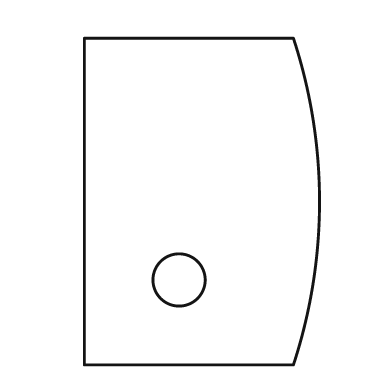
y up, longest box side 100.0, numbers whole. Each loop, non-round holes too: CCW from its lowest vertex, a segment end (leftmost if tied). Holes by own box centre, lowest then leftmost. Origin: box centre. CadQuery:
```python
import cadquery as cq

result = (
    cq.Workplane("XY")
    .moveTo(-36.0, -50.0)
    .lineTo(28.0, -50.0)
    .threePointArc((36.0, 0.0), (28.0, 50.0))
    .lineTo(-36.0, 50.0)
    .close()
    .moveTo(-7.0, -24.0)
    .circle(8.0)
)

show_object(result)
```